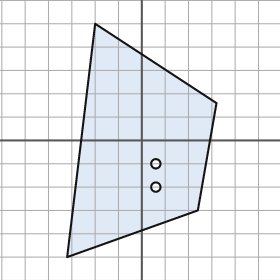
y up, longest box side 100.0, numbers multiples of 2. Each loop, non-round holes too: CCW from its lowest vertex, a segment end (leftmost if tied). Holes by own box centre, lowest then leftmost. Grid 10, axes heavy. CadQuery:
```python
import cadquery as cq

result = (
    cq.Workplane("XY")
    .moveTo(-32.0, -50.0)
    .lineTo(24.0, -30.0)
    .lineTo(32.0, 16.0)
    .lineTo(-20.0, 50.0)
    .close()
    .moveTo(6.0, -20.0)
    .circle(2.0)
    .moveTo(6.0, -10.0)
    .circle(2.0)
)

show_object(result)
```